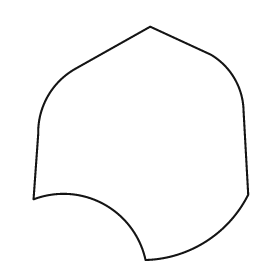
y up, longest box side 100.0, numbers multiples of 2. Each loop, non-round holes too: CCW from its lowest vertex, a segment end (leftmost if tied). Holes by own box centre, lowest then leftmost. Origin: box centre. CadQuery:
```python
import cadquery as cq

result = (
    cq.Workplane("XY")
    .moveTo(2.0, -50.0)
    .threePointArc((28.0, -42.0), (46.0, -22.0))
    .lineTo(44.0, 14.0)
    .threePointArc((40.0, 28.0), (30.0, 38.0))
    .lineTo(4.0, 50.0)
    .lineTo(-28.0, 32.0)
    .threePointArc((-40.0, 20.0), (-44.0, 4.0))
    .lineTo(-46.0, -24.0)
    .threePointArc((-16.0, -26.0), (2.0, -50.0))
    .close()
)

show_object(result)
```